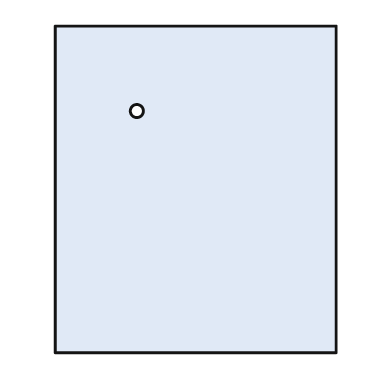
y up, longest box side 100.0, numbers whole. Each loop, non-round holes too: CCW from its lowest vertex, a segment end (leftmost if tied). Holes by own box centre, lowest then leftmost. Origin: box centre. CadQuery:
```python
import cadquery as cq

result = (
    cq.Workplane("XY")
    .moveTo(-43.0, -50.0)
    .lineTo(43.0, -50.0)
    .lineTo(43.0, 50.0)
    .lineTo(-43.0, 50.0)
    .close()
    .moveTo(-18.0, 24.0)
    .circle(2.0)
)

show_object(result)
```